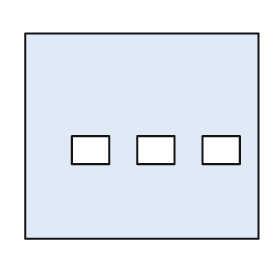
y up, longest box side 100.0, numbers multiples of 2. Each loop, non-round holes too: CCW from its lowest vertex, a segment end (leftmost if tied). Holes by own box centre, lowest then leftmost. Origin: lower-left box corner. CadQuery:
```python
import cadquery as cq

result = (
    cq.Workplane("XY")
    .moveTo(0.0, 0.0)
    .lineTo(100.0, 0.0)
    .lineTo(100.0, 88.0)
    .lineTo(0.0, 88.0)
    .close()
    .moveTo(20.0, 32.0)
    .lineTo(36.0, 32.0)
    .lineTo(36.0, 44.0)
    .lineTo(20.0, 44.0)
    .close()
    .moveTo(48.0, 32.0)
    .lineTo(64.0, 32.0)
    .lineTo(64.0, 44.0)
    .lineTo(48.0, 44.0)
    .close()
    .moveTo(76.0, 32.0)
    .lineTo(92.0, 32.0)
    .lineTo(92.0, 44.0)
    .lineTo(76.0, 44.0)
    .close()
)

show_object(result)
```